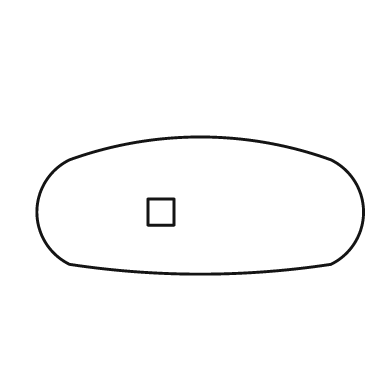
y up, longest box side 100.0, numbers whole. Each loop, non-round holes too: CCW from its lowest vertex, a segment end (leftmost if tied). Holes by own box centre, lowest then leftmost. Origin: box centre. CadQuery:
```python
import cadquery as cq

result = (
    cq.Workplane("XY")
    .moveTo(-40.0, -18.0)
    .threePointArc((0.0, -21.0), (40.0, -18.0))
    .threePointArc((50.0, -2.0), (40.0, 14.0))
    .threePointArc((0.0, 21.0), (-40.0, 14.0))
    .threePointArc((-50.0, -2.0), (-40.0, -18.0))
    .close()
    .moveTo(-16.0, -6.0)
    .lineTo(-8.0, -6.0)
    .lineTo(-8.0, 2.0)
    .lineTo(-16.0, 2.0)
    .close()
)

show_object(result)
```